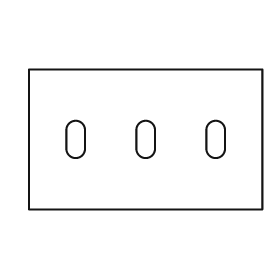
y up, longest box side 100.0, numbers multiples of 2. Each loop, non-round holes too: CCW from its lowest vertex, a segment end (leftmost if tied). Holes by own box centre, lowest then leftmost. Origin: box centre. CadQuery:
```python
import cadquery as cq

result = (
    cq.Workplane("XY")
    .moveTo(-50.0, -30.0)
    .lineTo(50.0, -30.0)
    .lineTo(50.0, 30.0)
    .lineTo(-50.0, 30.0)
    .close()
    .moveTo(-34.0, -4.0)
    .threePointArc((-30.0, -8.0), (-26.0, -4.0))
    .lineTo(-26.0, 4.0)
    .threePointArc((-30.0, 8.0), (-34.0, 4.0))
    .close()
    .moveTo(-4.0, -4.0)
    .threePointArc((0.0, -8.0), (4.0, -4.0))
    .lineTo(4.0, 4.0)
    .threePointArc((0.0, 8.0), (-4.0, 4.0))
    .close()
    .moveTo(26.0, -4.0)
    .threePointArc((30.0, -8.0), (34.0, -4.0))
    .lineTo(34.0, 4.0)
    .threePointArc((30.0, 8.0), (26.0, 4.0))
    .close()
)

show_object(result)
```